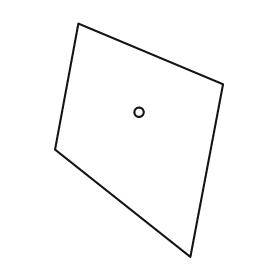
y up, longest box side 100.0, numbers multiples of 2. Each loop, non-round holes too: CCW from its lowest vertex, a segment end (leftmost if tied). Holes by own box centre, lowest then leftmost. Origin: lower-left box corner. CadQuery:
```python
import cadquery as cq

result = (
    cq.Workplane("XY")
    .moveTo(58.0, 0.0)
    .lineTo(72.0, 74.0)
    .lineTo(10.0, 100.0)
    .lineTo(0.0, 46.0)
    .close()
    .moveTo(36.0, 62.0)
    .circle(2.0)
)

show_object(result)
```